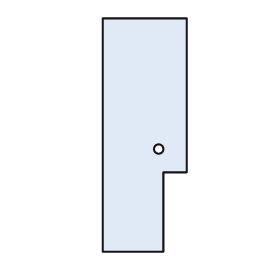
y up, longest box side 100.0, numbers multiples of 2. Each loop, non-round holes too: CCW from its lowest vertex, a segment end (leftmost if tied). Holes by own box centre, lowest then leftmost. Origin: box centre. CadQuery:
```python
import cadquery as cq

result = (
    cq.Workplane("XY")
    .moveTo(-18.0, -50.0)
    .lineTo(8.0, -50.0)
    .lineTo(8.0, -16.0)
    .lineTo(18.0, -16.0)
    .lineTo(18.0, 50.0)
    .lineTo(-18.0, 50.0)
    .close()
    .moveTo(6.0, -6.0)
    .circle(2.0)
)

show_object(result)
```